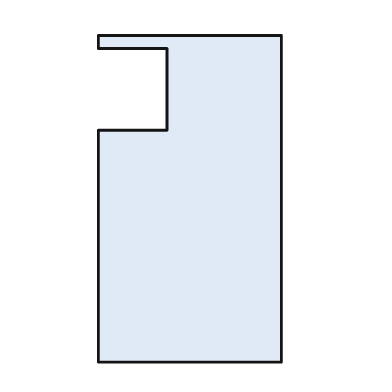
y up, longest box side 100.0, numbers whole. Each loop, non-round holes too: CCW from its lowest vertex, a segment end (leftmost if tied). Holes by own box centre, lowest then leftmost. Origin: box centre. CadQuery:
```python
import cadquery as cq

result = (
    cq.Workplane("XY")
    .moveTo(-28.0, -50.0)
    .lineTo(28.0, -50.0)
    .lineTo(28.0, 50.0)
    .lineTo(-28.0, 50.0)
    .lineTo(-28.0, 46.0)
    .lineTo(-7.0, 46.0)
    .lineTo(-7.0, 21.0)
    .lineTo(-28.0, 21.0)
    .close()
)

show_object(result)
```